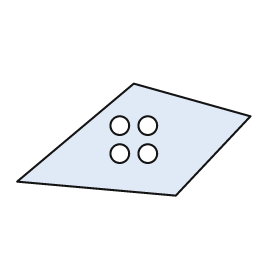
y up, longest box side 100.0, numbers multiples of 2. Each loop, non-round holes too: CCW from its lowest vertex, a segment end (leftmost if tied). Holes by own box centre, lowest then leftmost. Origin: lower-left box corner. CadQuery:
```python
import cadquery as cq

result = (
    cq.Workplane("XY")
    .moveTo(68.0, 0.0)
    .lineTo(100.0, 34.0)
    .lineTo(50.0, 48.0)
    .lineTo(0.0, 6.0)
    .close()
    .moveTo(44.0, 18.0)
    .circle(4.0)
    .moveTo(56.0, 18.0)
    .circle(4.0)
    .moveTo(44.0, 30.0)
    .circle(4.0)
    .moveTo(56.0, 30.0)
    .circle(4.0)
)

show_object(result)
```